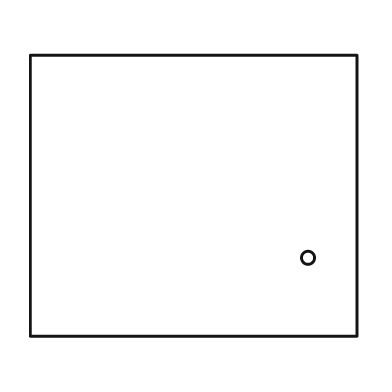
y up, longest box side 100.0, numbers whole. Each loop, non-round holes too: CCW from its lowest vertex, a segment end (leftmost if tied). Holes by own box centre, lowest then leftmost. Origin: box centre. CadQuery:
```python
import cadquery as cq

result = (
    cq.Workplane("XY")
    .moveTo(-50.0, -43.0)
    .lineTo(50.0, -43.0)
    .lineTo(50.0, 43.0)
    .lineTo(-50.0, 43.0)
    .close()
    .moveTo(35.0, -19.0)
    .circle(2.0)
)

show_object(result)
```